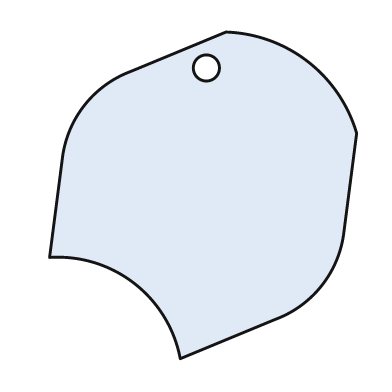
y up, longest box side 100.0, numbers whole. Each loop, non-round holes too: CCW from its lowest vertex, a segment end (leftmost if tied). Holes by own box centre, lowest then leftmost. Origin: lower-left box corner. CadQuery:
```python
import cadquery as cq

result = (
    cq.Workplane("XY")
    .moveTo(40.0, 0.0)
    .lineTo(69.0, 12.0)
    .threePointArc((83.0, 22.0), (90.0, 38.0))
    .lineTo(94.0, 69.0)
    .threePointArc((79.0, 91.0), (54.0, 100.0))
    .lineTo(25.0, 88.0)
    .threePointArc((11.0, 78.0), (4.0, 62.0))
    .lineTo(0.0, 31.0)
    .threePointArc((26.0, 23.0), (40.0, 0.0))
    .close()
    .moveTo(48.0, 89.0)
    .circle(4.0)
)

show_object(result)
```